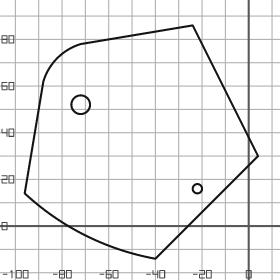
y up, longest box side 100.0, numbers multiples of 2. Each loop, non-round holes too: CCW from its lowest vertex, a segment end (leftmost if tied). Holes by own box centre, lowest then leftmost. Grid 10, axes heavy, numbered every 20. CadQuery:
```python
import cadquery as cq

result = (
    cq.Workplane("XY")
    .moveTo(-40.0, -14.0)
    .lineTo(4.0, 30.0)
    .lineTo(-24.0, 86.0)
    .lineTo(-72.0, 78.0)
    .threePointArc((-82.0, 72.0), (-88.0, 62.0))
    .lineTo(-96.0, 14.0)
    .threePointArc((-70.0, -4.0), (-40.0, -14.0))
    .close()
    .moveTo(-22.0, 16.0)
    .circle(2.0)
    .moveTo(-72.0, 52.0)
    .circle(4.0)
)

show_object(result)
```